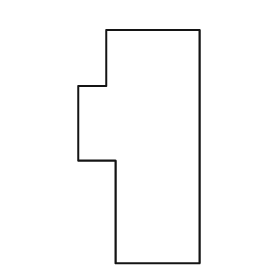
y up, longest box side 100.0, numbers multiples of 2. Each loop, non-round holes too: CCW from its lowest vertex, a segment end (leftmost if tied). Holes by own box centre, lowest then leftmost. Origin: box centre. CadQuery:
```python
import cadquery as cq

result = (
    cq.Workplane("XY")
    .moveTo(-10.0, -50.0)
    .lineTo(26.0, -50.0)
    .lineTo(26.0, 50.0)
    .lineTo(-14.0, 50.0)
    .lineTo(-14.0, 26.0)
    .lineTo(-26.0, 26.0)
    .lineTo(-26.0, -6.0)
    .lineTo(-10.0, -6.0)
    .close()
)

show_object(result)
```